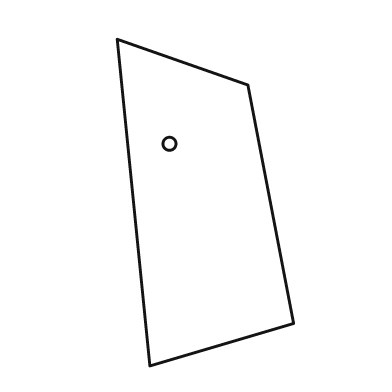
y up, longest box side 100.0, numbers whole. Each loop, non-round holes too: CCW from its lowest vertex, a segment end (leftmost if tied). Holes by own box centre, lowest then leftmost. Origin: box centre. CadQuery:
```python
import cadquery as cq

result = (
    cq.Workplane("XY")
    .moveTo(-17.0, -50.0)
    .lineTo(27.0, -37.0)
    .lineTo(13.0, 36.0)
    .lineTo(-27.0, 50.0)
    .close()
    .moveTo(-11.0, 18.0)
    .circle(2.0)
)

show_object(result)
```